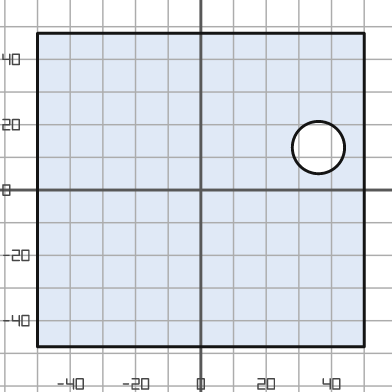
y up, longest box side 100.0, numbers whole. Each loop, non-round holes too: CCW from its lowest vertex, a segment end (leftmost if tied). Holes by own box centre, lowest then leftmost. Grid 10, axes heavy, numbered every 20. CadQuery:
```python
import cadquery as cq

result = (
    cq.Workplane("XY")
    .moveTo(-50.0, -48.0)
    .lineTo(50.0, -48.0)
    .lineTo(50.0, 48.0)
    .lineTo(-50.0, 48.0)
    .close()
    .moveTo(36.0, 13.0)
    .circle(8.0)
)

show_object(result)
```